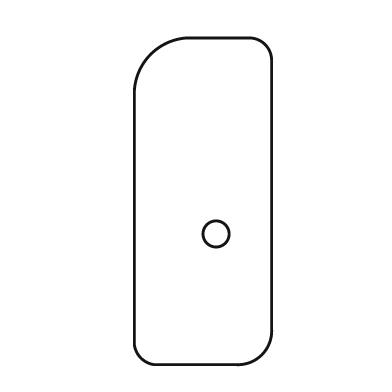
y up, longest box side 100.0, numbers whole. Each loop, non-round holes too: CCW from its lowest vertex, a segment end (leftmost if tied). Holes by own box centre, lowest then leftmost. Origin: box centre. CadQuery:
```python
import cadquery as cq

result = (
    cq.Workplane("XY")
    .moveTo(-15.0, -50.0)
    .lineTo(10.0, -50.0)
    .threePointArc((18.0, -47.0), (21.0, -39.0))
    .lineTo(21.0, 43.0)
    .threePointArc((19.0, 48.0), (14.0, 50.0))
    .lineTo(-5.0, 50.0)
    .threePointArc((-16.0, 45.0), (-21.0, 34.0))
    .lineTo(-21.0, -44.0)
    .threePointArc((-19.0, -48.0), (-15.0, -50.0))
    .close()
    .moveTo(4.0, -10.0)
    .circle(4.0)
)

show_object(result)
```